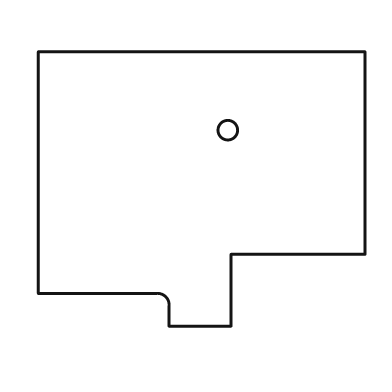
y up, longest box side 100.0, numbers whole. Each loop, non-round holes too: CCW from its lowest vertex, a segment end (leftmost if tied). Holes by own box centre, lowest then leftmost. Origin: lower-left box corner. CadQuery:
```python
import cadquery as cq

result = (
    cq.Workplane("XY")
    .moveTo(40.0, 0.0)
    .lineTo(59.0, 0.0)
    .lineTo(59.0, 22.0)
    .lineTo(100.0, 22.0)
    .lineTo(100.0, 84.0)
    .lineTo(0.0, 84.0)
    .lineTo(0.0, 10.0)
    .lineTo(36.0, 10.0)
    .threePointArc((39.0, 9.0), (40.0, 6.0))
    .close()
    .moveTo(58.0, 60.0)
    .circle(3.0)
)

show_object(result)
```